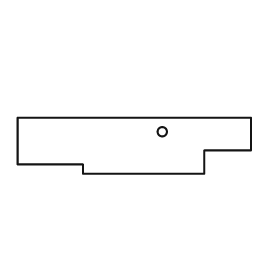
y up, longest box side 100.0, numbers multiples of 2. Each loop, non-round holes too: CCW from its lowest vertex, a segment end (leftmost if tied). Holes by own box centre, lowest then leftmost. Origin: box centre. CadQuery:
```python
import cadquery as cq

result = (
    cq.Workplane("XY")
    .moveTo(-22.0, -12.0)
    .lineTo(30.0, -12.0)
    .lineTo(30.0, -2.0)
    .lineTo(50.0, -2.0)
    .lineTo(50.0, 12.0)
    .lineTo(-50.0, 12.0)
    .lineTo(-50.0, -8.0)
    .lineTo(-22.0, -8.0)
    .close()
    .moveTo(12.0, 6.0)
    .circle(2.0)
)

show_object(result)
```